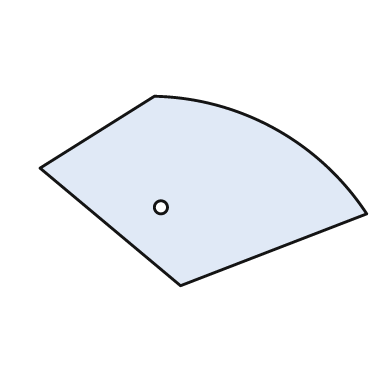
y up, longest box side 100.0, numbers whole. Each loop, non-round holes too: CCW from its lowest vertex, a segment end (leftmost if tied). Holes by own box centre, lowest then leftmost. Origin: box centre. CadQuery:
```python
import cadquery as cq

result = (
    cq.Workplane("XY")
    .moveTo(-7.0, -29.0)
    .lineTo(50.0, -7.0)
    .threePointArc((22.0, 19.0), (-15.0, 29.0))
    .lineTo(-50.0, 7.0)
    .close()
    .moveTo(-13.0, -5.0)
    .circle(2.0)
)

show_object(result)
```